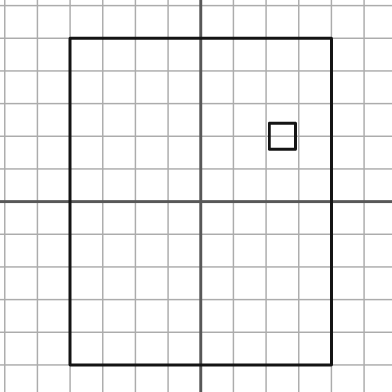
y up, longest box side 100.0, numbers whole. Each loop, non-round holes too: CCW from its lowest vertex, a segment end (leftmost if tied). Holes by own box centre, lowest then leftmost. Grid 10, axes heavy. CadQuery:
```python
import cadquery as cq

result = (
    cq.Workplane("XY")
    .moveTo(-40.0, -50.0)
    .lineTo(40.0, -50.0)
    .lineTo(40.0, 50.0)
    .lineTo(-40.0, 50.0)
    .close()
    .moveTo(21.0, 16.0)
    .lineTo(29.0, 16.0)
    .lineTo(29.0, 24.0)
    .lineTo(21.0, 24.0)
    .close()
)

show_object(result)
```